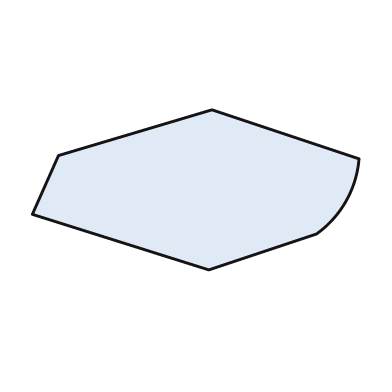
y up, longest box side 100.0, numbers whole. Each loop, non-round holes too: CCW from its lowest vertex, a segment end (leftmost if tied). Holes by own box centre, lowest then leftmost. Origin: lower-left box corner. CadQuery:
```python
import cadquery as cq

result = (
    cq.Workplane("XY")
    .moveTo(54.0, 0.0)
    .lineTo(87.0, 11.0)
    .threePointArc((96.0, 21.0), (100.0, 34.0))
    .lineTo(55.0, 49.0)
    .lineTo(8.0, 35.0)
    .lineTo(0.0, 17.0)
    .close()
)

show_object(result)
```